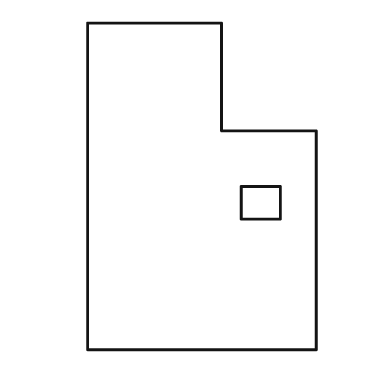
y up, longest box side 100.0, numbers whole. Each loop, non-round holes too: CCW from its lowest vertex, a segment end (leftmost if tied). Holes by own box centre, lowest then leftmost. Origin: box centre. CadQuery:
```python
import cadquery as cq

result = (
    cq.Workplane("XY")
    .moveTo(-35.0, -50.0)
    .lineTo(35.0, -50.0)
    .lineTo(35.0, 17.0)
    .lineTo(6.0, 17.0)
    .lineTo(6.0, 50.0)
    .lineTo(-35.0, 50.0)
    .close()
    .moveTo(12.0, -10.0)
    .lineTo(24.0, -10.0)
    .lineTo(24.0, 0.0)
    .lineTo(12.0, 0.0)
    .close()
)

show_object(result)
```